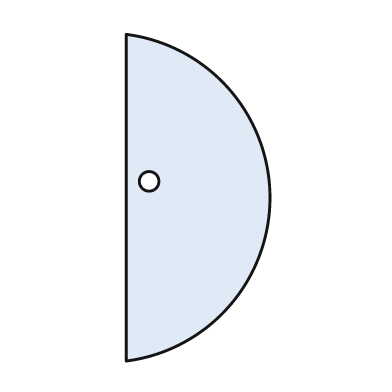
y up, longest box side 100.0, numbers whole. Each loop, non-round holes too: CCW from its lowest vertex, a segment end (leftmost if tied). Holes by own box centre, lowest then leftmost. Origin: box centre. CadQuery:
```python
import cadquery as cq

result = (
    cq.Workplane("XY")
    .moveTo(-22.0, -50.0)
    .threePointArc((22.0, 0.0), (-22.0, 50.0))
    .close()
    .moveTo(-15.0, 5.0)
    .circle(3.0)
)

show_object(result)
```